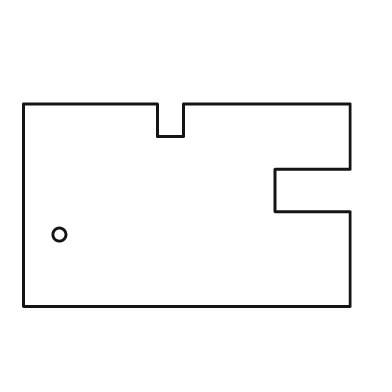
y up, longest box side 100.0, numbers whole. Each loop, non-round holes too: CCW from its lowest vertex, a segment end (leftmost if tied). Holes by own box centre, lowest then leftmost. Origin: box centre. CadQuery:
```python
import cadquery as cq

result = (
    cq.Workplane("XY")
    .moveTo(-50.0, -31.0)
    .lineTo(50.0, -31.0)
    .lineTo(50.0, -2.0)
    .lineTo(27.0, -2.0)
    .lineTo(27.0, 11.0)
    .lineTo(50.0, 11.0)
    .lineTo(50.0, 31.0)
    .lineTo(-1.0, 31.0)
    .lineTo(-1.0, 21.0)
    .lineTo(-9.0, 21.0)
    .lineTo(-9.0, 31.0)
    .lineTo(-50.0, 31.0)
    .close()
    .moveTo(-39.0, -9.0)
    .circle(2.0)
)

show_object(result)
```